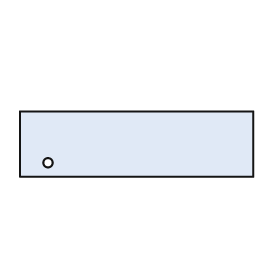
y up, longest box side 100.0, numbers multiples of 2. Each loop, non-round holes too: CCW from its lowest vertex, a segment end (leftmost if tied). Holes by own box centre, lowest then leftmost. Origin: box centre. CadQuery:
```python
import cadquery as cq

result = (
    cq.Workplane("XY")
    .moveTo(-50.0, -14.0)
    .lineTo(50.0, -14.0)
    .lineTo(50.0, 14.0)
    .lineTo(-50.0, 14.0)
    .close()
    .moveTo(-38.0, -8.0)
    .circle(2.0)
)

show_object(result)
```